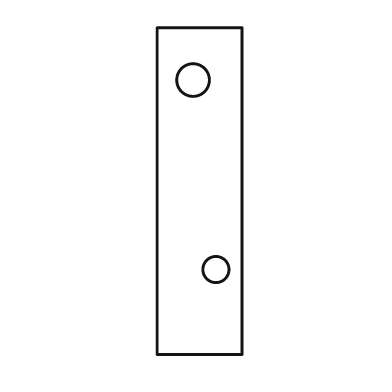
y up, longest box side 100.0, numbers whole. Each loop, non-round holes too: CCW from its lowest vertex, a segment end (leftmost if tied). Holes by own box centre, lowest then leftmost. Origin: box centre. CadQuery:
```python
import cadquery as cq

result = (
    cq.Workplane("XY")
    .moveTo(-13.0, -50.0)
    .lineTo(13.0, -50.0)
    .lineTo(13.0, 50.0)
    .lineTo(-13.0, 50.0)
    .close()
    .moveTo(5.0, -24.0)
    .circle(4.0)
    .moveTo(-2.0, 34.0)
    .circle(5.0)
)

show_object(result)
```